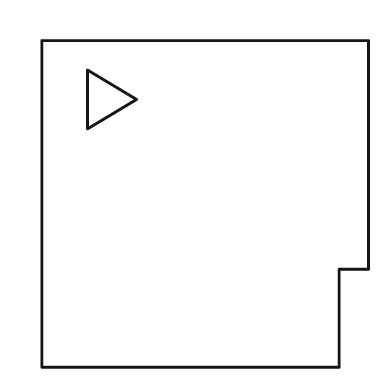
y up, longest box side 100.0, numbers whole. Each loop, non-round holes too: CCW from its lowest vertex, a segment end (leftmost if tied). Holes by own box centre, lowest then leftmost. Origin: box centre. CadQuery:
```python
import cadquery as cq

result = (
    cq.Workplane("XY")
    .moveTo(-50.0, -50.0)
    .lineTo(41.0, -50.0)
    .lineTo(41.0, -20.0)
    .lineTo(50.0, -20.0)
    .lineTo(50.0, 50.0)
    .lineTo(-50.0, 50.0)
    .close()
    .moveTo(-36.0, 23.0)
    .lineTo(-21.0, 32.0)
    .lineTo(-36.0, 41.0)
    .close()
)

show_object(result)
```